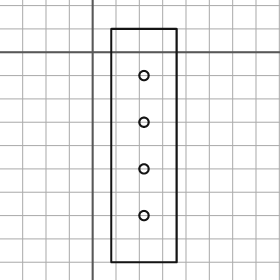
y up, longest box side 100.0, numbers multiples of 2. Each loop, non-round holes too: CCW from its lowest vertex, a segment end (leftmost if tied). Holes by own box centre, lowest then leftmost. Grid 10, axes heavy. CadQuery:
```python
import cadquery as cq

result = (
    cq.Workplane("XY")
    .moveTo(8.0, -90.0)
    .lineTo(36.0, -90.0)
    .lineTo(36.0, 10.0)
    .lineTo(8.0, 10.0)
    .close()
    .moveTo(22.0, -70.0)
    .circle(2.0)
    .moveTo(22.0, -50.0)
    .circle(2.0)
    .moveTo(22.0, -30.0)
    .circle(2.0)
    .moveTo(22.0, -10.0)
    .circle(2.0)
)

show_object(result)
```